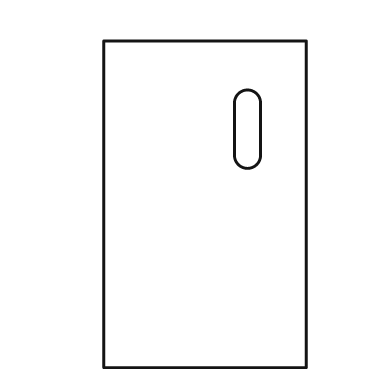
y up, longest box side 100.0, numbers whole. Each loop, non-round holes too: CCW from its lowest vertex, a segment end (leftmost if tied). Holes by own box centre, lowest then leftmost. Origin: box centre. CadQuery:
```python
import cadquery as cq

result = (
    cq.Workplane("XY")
    .moveTo(-31.0, -50.0)
    .lineTo(31.0, -50.0)
    .lineTo(31.0, 50.0)
    .lineTo(-31.0, 50.0)
    .close()
    .moveTo(9.0, 15.0)
    .threePointArc((13.0, 11.0), (17.0, 15.0))
    .lineTo(17.0, 31.0)
    .threePointArc((13.0, 35.0), (9.0, 31.0))
    .close()
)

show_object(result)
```